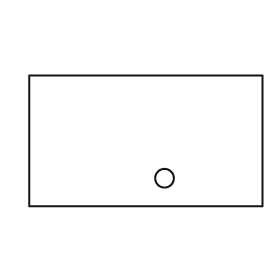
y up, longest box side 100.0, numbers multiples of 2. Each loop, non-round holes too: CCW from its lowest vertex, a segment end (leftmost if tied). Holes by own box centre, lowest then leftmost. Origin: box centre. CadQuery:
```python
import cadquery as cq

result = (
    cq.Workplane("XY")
    .moveTo(-50.0, -28.0)
    .lineTo(50.0, -28.0)
    .lineTo(50.0, 28.0)
    .lineTo(-50.0, 28.0)
    .close()
    .moveTo(8.0, -16.0)
    .circle(4.0)
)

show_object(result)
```